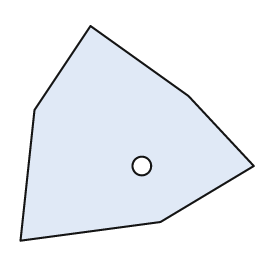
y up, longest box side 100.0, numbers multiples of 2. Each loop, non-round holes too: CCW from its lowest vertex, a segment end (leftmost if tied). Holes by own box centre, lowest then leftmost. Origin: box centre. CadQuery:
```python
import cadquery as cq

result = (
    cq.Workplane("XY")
    .moveTo(-50.0, -46.0)
    .lineTo(10.0, -38.0)
    .lineTo(50.0, -14.0)
    .lineTo(22.0, 16.0)
    .lineTo(-20.0, 46.0)
    .lineTo(-44.0, 10.0)
    .close()
    .moveTo(2.0, -14.0)
    .circle(4.0)
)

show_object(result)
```